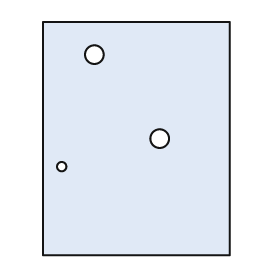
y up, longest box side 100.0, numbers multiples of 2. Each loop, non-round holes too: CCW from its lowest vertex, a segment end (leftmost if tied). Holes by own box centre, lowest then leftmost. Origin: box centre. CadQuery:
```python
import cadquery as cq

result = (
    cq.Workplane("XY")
    .moveTo(-40.0, -50.0)
    .lineTo(40.0, -50.0)
    .lineTo(40.0, 50.0)
    .lineTo(-40.0, 50.0)
    .close()
    .moveTo(-32.0, -12.0)
    .circle(2.0)
    .moveTo(10.0, 0.0)
    .circle(4.0)
    .moveTo(-18.0, 36.0)
    .circle(4.0)
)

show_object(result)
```